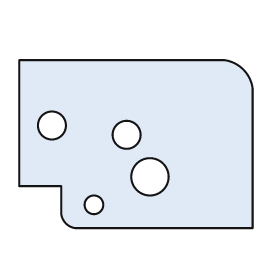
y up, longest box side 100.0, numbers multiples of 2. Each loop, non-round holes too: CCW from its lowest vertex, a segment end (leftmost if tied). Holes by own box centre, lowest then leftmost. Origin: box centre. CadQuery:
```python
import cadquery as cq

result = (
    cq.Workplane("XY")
    .moveTo(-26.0, -36.0)
    .lineTo(50.0, -36.0)
    .lineTo(50.0, 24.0)
    .threePointArc((46.0, 32.0), (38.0, 36.0))
    .lineTo(-50.0, 36.0)
    .lineTo(-50.0, -18.0)
    .lineTo(-32.0, -18.0)
    .lineTo(-32.0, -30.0)
    .threePointArc((-30.0, -34.0), (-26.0, -36.0))
    .close()
    .moveTo(-18.0, -26.0)
    .circle(4.0)
    .moveTo(6.0, -14.0)
    .circle(8.0)
    .moveTo(-4.0, 4.0)
    .circle(6.0)
    .moveTo(-36.0, 8.0)
    .circle(6.0)
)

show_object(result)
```